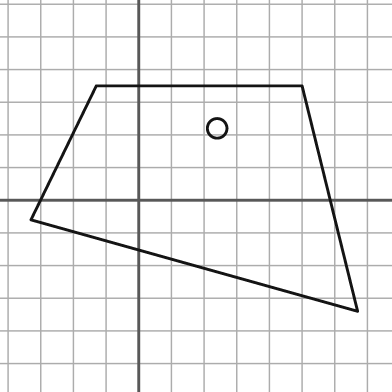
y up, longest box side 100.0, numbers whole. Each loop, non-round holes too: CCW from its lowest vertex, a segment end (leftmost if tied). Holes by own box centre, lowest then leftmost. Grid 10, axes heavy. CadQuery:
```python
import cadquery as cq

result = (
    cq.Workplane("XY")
    .moveTo(67.0, -34.0)
    .lineTo(50.0, 35.0)
    .lineTo(-13.0, 35.0)
    .lineTo(-33.0, -6.0)
    .close()
    .moveTo(24.0, 22.0)
    .circle(3.0)
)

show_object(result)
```